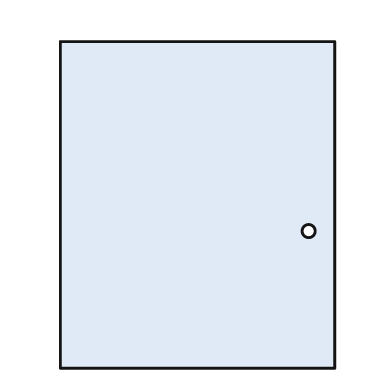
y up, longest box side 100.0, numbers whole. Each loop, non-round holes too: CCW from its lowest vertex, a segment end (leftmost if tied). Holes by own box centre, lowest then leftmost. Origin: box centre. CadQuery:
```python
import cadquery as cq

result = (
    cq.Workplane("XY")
    .moveTo(-42.0, -50.0)
    .lineTo(42.0, -50.0)
    .lineTo(42.0, 50.0)
    .lineTo(-42.0, 50.0)
    .close()
    .moveTo(34.0, -8.0)
    .circle(2.0)
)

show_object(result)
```